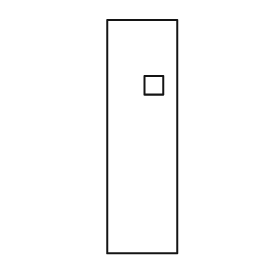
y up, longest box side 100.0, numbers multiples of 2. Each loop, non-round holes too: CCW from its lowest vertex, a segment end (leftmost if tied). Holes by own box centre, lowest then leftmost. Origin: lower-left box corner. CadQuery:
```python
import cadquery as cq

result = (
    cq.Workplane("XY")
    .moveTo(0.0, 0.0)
    .lineTo(30.0, 0.0)
    .lineTo(30.0, 100.0)
    .lineTo(0.0, 100.0)
    .close()
    .moveTo(16.0, 68.0)
    .lineTo(24.0, 68.0)
    .lineTo(24.0, 76.0)
    .lineTo(16.0, 76.0)
    .close()
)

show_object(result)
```